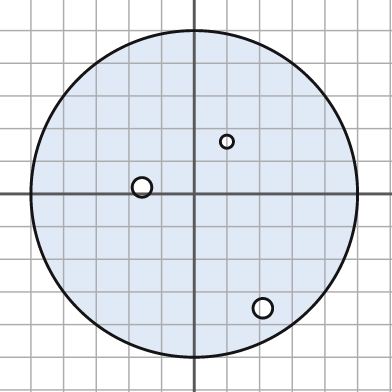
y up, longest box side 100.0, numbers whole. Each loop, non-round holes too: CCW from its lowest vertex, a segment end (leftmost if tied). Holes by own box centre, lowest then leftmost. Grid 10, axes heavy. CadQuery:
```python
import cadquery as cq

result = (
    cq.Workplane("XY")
    .moveTo(0.0, 0.0)
    .circle(50.0)
    .moveTo(21.0, -35.0)
    .circle(3.0)
    .moveTo(-16.0, 2.0)
    .circle(3.0)
    .moveTo(10.0, 16.0)
    .circle(2.0)
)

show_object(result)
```